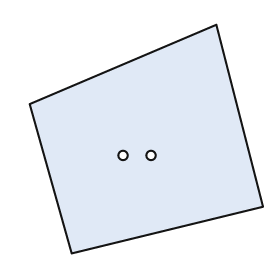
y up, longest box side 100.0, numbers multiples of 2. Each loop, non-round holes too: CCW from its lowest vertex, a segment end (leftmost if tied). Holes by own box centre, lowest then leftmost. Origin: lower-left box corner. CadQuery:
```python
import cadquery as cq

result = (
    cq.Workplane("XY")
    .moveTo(18.0, 0.0)
    .lineTo(100.0, 20.0)
    .lineTo(80.0, 98.0)
    .lineTo(0.0, 64.0)
    .close()
    .moveTo(40.0, 42.0)
    .circle(2.0)
    .moveTo(52.0, 42.0)
    .circle(2.0)
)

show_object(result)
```